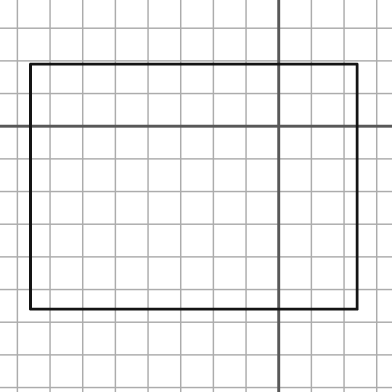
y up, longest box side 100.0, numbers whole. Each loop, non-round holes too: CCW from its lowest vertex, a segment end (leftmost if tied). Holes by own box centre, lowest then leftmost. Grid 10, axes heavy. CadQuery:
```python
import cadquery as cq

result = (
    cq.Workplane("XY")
    .moveTo(-76.0, -56.0)
    .lineTo(24.0, -56.0)
    .lineTo(24.0, 19.0)
    .lineTo(-76.0, 19.0)
    .close()
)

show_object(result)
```